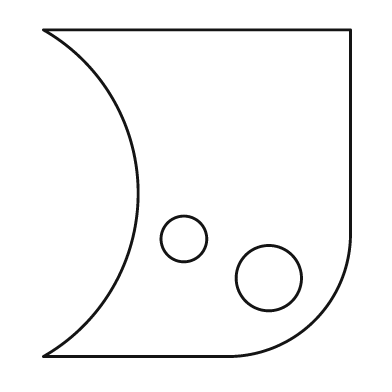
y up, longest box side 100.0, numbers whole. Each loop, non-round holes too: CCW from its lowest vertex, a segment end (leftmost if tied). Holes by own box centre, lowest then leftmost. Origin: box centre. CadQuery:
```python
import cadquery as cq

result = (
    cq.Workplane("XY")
    .moveTo(-47.0, -50.0)
    .lineTo(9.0, -50.0)
    .threePointArc((36.0, -39.0), (47.0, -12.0))
    .lineTo(47.0, 50.0)
    .lineTo(-47.0, 50.0)
    .threePointArc((-18.0, 0.0), (-47.0, -50.0))
    .close()
    .moveTo(22.0, -26.0)
    .circle(10.0)
    .moveTo(-4.0, -14.0)
    .circle(7.0)
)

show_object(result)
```